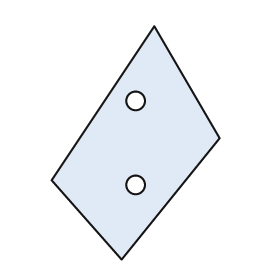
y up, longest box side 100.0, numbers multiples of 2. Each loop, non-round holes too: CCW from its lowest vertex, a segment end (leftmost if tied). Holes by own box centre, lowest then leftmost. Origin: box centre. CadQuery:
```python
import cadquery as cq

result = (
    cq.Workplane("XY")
    .moveTo(-6.0, -50.0)
    .lineTo(36.0, 2.0)
    .lineTo(8.0, 50.0)
    .lineTo(-36.0, -16.0)
    .close()
    .moveTo(0.0, -18.0)
    .circle(4.0)
    .moveTo(0.0, 18.0)
    .circle(4.0)
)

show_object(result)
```